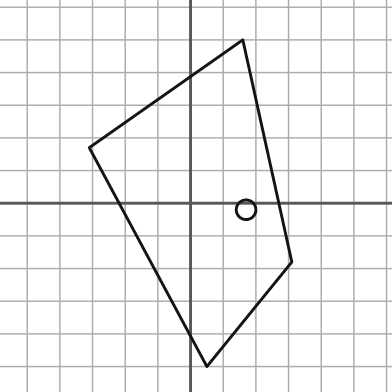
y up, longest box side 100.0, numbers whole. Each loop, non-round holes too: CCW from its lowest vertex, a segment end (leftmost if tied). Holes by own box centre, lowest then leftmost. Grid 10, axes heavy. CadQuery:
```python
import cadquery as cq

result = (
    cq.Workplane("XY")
    .moveTo(5.0, -50.0)
    .lineTo(31.0, -18.0)
    .lineTo(16.0, 50.0)
    .lineTo(-31.0, 17.0)
    .close()
    .moveTo(17.0, -2.0)
    .circle(3.0)
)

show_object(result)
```